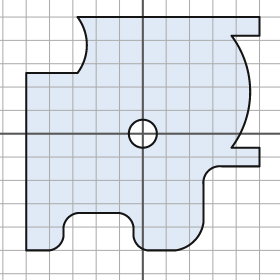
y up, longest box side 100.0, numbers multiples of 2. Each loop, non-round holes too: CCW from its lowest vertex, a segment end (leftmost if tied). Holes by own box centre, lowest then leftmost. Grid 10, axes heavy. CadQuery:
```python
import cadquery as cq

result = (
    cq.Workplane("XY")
    .moveTo(-50.0, -50.0)
    .lineTo(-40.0, -50.0)
    .threePointArc((-36.0, -48.0), (-34.0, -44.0))
    .lineTo(-34.0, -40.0)
    .threePointArc((-32.0, -36.0), (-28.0, -34.0))
    .lineTo(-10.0, -34.0)
    .threePointArc((-6.0, -36.0), (-4.0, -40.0))
    .lineTo(-4.0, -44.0)
    .threePointArc((-2.0, -48.0), (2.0, -50.0))
    .lineTo(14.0, -50.0)
    .threePointArc((22.0, -46.0), (26.0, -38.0))
    .lineTo(26.0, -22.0)
    .threePointArc((28.0, -16.0), (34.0, -14.0))
    .lineTo(50.0, -14.0)
    .lineTo(50.0, -6.0)
    .lineTo(38.0, -6.0)
    .threePointArc((46.0, 18.0), (38.0, 42.0))
    .lineTo(50.0, 42.0)
    .lineTo(50.0, 50.0)
    .lineTo(-28.0, 50.0)
    .threePointArc((-24.0, 38.0), (-28.0, 26.0))
    .lineTo(-50.0, 26.0)
    .close()
    .moveTo(0.0, 0.0)
    .circle(6.0)
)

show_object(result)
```